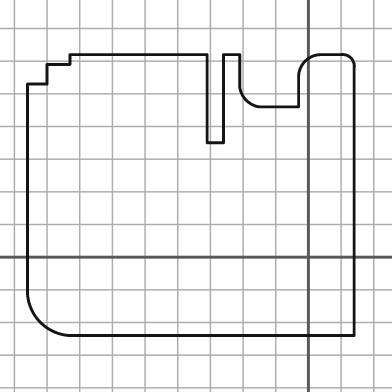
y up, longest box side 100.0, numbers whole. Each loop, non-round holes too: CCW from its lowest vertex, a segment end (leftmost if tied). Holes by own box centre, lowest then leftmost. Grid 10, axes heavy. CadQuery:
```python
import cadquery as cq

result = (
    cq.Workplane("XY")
    .moveTo(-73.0, -24.0)
    .lineTo(14.0, -24.0)
    .lineTo(14.0, 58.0)
    .threePointArc((13.0, 61.0), (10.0, 62.0))
    .lineTo(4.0, 62.0)
    .threePointArc((-1.0, 60.0), (-3.0, 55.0))
    .lineTo(-3.0, 46.0)
    .lineTo(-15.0, 46.0)
    .threePointArc((-19.0, 48.0), (-21.0, 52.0))
    .lineTo(-21.0, 62.0)
    .lineTo(-26.0, 62.0)
    .lineTo(-26.0, 35.0)
    .lineTo(-31.0, 35.0)
    .lineTo(-31.0, 62.0)
    .lineTo(-73.0, 62.0)
    .lineTo(-73.0, 59.0)
    .lineTo(-80.0, 59.0)
    .lineTo(-80.0, 53.0)
    .lineTo(-86.0, 53.0)
    .lineTo(-86.0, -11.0)
    .threePointArc((-82.0, -20.0), (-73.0, -24.0))
    .close()
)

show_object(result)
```